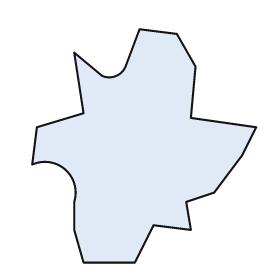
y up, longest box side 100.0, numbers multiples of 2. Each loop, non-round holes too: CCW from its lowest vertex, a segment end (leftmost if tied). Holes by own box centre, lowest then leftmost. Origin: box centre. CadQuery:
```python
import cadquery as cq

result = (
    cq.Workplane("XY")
    .moveTo(-26.0, -50.0)
    .lineTo(-4.0, -50.0)
    .lineTo(4.0, -34.0)
    .lineTo(20.0, -36.0)
    .lineTo(18.0, -24.0)
    .lineTo(30.0, -20.0)
    .lineTo(42.0, -4.0)
    .lineTo(48.0, 8.0)
    .lineTo(20.0, 12.0)
    .lineTo(22.0, 34.0)
    .lineTo(14.0, 48.0)
    .lineTo(-2.0, 50.0)
    .lineTo(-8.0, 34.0)
    .threePointArc((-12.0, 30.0), (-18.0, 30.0))
    .lineTo(-30.0, 40.0)
    .lineTo(-26.0, 14.0)
    .lineTo(-46.0, 8.0)
    .lineTo(-48.0, -8.0)
    .threePointArc((-34.0, -10.0), (-30.0, -24.0))
    .lineTo(-30.0, -36.0)
    .close()
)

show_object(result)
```